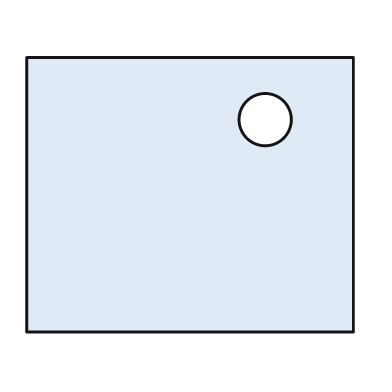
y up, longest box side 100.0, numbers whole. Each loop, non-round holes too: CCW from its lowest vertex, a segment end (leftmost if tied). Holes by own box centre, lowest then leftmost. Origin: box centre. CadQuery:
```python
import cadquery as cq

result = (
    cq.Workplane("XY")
    .moveTo(-50.0, -42.0)
    .lineTo(50.0, -42.0)
    .lineTo(50.0, 42.0)
    .lineTo(-50.0, 42.0)
    .close()
    .moveTo(23.0, 23.0)
    .circle(8.0)
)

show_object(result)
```